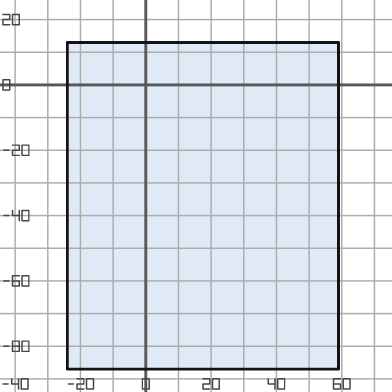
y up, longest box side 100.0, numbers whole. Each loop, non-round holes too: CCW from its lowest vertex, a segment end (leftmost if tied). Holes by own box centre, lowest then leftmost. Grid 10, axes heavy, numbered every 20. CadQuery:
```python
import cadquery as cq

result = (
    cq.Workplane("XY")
    .moveTo(-24.0, -87.0)
    .lineTo(59.0, -87.0)
    .lineTo(59.0, 13.0)
    .lineTo(-24.0, 13.0)
    .close()
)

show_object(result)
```